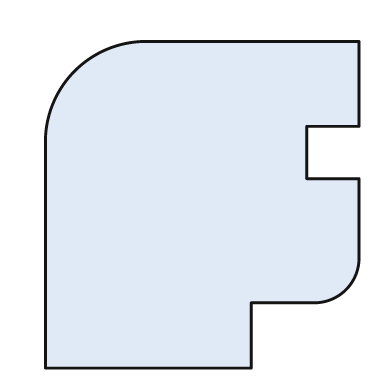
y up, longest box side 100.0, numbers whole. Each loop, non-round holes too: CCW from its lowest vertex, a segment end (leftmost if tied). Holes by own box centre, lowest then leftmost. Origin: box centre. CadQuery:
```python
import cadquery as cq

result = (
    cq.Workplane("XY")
    .moveTo(-48.0, -50.0)
    .lineTo(15.0, -50.0)
    .lineTo(15.0, -30.0)
    .lineTo(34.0, -30.0)
    .threePointArc((44.0, -26.0), (48.0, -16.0))
    .lineTo(48.0, 8.0)
    .lineTo(32.0, 8.0)
    .lineTo(32.0, 24.0)
    .lineTo(48.0, 24.0)
    .lineTo(48.0, 50.0)
    .lineTo(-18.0, 50.0)
    .threePointArc((-39.0, 41.0), (-48.0, 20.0))
    .close()
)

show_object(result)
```